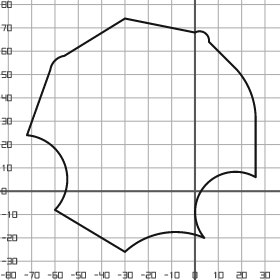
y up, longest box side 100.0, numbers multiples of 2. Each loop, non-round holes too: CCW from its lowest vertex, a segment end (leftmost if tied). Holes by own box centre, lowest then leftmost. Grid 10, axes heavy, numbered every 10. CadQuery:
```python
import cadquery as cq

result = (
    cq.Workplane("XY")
    .moveTo(-30.0, -26.0)
    .threePointArc((-14.0, -18.0), (4.0, -20.0))
    .threePointArc((4.0, 2.0), (26.0, 6.0))
    .lineTo(26.0, 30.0)
    .threePointArc((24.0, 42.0), (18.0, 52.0))
    .lineTo(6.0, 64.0)
    .threePointArc((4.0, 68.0), (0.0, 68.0))
    .lineTo(-30.0, 74.0)
    .lineTo(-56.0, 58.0)
    .threePointArc((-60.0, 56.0), (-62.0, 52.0))
    .lineTo(-72.0, 24.0)
    .threePointArc((-56.0, 12.0), (-60.0, -8.0))
    .close()
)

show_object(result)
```